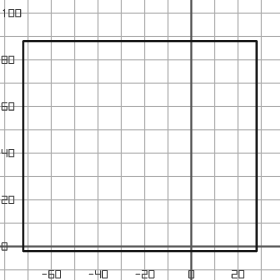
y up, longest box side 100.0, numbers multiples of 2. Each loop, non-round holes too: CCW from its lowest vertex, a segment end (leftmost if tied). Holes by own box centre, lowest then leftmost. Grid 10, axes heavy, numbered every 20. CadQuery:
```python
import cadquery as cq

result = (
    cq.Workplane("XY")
    .moveTo(-72.0, -2.0)
    .lineTo(28.0, -2.0)
    .lineTo(28.0, 88.0)
    .lineTo(-72.0, 88.0)
    .close()
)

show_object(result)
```